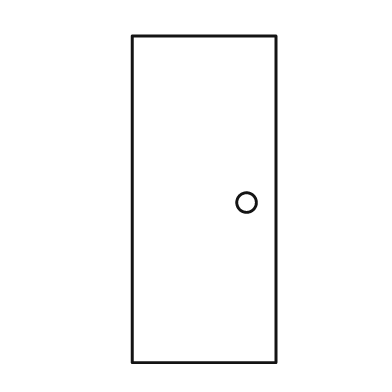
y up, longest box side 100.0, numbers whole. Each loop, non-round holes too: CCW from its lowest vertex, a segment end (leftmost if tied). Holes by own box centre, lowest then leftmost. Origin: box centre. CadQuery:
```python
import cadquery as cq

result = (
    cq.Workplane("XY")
    .moveTo(-22.0, -50.0)
    .lineTo(22.0, -50.0)
    .lineTo(22.0, 50.0)
    .lineTo(-22.0, 50.0)
    .close()
    .moveTo(13.0, -1.0)
    .circle(3.0)
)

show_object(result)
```